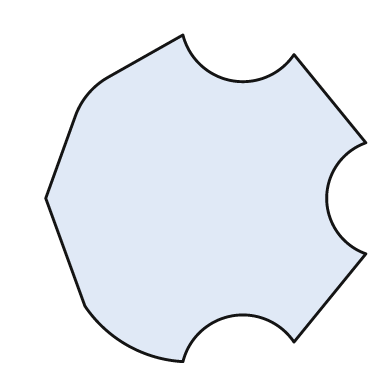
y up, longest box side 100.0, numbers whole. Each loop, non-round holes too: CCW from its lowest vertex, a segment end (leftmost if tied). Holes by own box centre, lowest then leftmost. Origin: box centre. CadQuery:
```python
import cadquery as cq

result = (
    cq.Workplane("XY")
    .moveTo(-7.0, -50.0)
    .threePointArc((8.0, -36.0), (27.0, -44.0))
    .lineTo(49.0, -17.0)
    .threePointArc((37.0, 0.0), (49.0, 17.0))
    .lineTo(27.0, 44.0)
    .threePointArc((8.0, 36.0), (-7.0, 50.0))
    .lineTo(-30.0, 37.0)
    .threePointArc((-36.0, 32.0), (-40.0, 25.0))
    .lineTo(-49.0, 0.0)
    .lineTo(-37.0, -33.0)
    .threePointArc((-24.0, -45.0), (-7.0, -50.0))
    .close()
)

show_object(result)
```